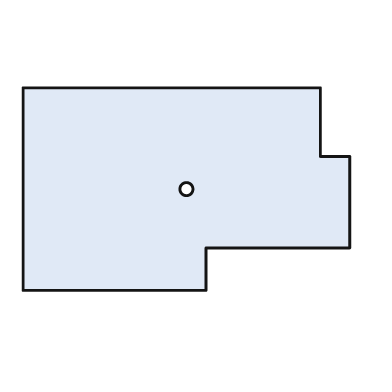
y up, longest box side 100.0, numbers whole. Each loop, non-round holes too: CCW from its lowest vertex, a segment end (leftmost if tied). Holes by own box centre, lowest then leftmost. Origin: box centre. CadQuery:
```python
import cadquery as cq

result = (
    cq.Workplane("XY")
    .moveTo(-50.0, -31.0)
    .lineTo(6.0, -31.0)
    .lineTo(6.0, -18.0)
    .lineTo(50.0, -18.0)
    .lineTo(50.0, 10.0)
    .lineTo(41.0, 10.0)
    .lineTo(41.0, 31.0)
    .lineTo(-50.0, 31.0)
    .close()
    .moveTo(0.0, 0.0)
    .circle(2.0)
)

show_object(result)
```